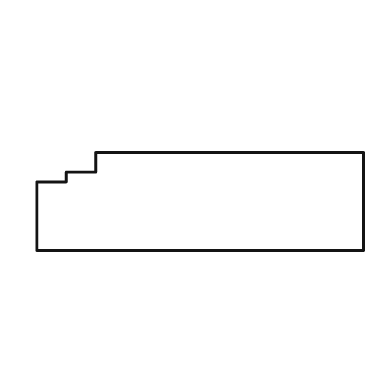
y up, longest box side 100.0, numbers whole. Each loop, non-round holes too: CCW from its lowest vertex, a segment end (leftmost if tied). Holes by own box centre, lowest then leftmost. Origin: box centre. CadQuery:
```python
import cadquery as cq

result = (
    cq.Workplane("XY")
    .moveTo(-50.0, -15.0)
    .lineTo(50.0, -15.0)
    .lineTo(50.0, 15.0)
    .lineTo(-32.0, 15.0)
    .lineTo(-32.0, 9.0)
    .lineTo(-41.0, 9.0)
    .lineTo(-41.0, 6.0)
    .lineTo(-50.0, 6.0)
    .close()
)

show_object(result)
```